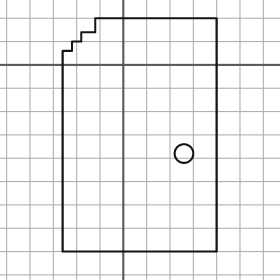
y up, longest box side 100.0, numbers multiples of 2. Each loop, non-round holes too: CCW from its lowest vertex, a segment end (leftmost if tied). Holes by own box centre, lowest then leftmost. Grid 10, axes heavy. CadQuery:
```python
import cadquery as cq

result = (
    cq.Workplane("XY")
    .moveTo(-26.0, -80.0)
    .lineTo(40.0, -80.0)
    .lineTo(40.0, 20.0)
    .lineTo(-12.0, 20.0)
    .lineTo(-12.0, 14.0)
    .lineTo(-18.0, 14.0)
    .lineTo(-18.0, 10.0)
    .lineTo(-22.0, 10.0)
    .lineTo(-22.0, 6.0)
    .lineTo(-26.0, 6.0)
    .close()
    .moveTo(26.0, -38.0)
    .circle(4.0)
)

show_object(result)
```